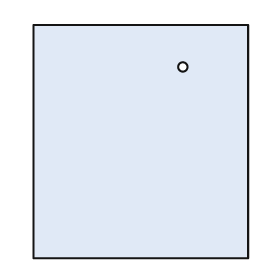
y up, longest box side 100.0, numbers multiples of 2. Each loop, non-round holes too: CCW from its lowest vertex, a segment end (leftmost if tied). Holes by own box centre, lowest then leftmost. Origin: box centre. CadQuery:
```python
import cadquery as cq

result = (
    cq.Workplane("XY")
    .moveTo(-46.0, -50.0)
    .lineTo(46.0, -50.0)
    .lineTo(46.0, 50.0)
    .lineTo(-46.0, 50.0)
    .close()
    .moveTo(18.0, 32.0)
    .circle(2.0)
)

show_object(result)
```